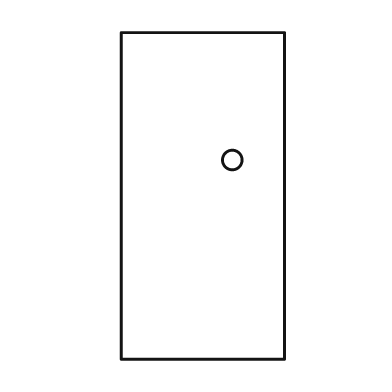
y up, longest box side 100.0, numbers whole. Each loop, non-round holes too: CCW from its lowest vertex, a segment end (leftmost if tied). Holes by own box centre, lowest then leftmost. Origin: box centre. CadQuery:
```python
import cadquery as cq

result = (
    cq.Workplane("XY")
    .moveTo(-25.0, -50.0)
    .lineTo(25.0, -50.0)
    .lineTo(25.0, 50.0)
    .lineTo(-25.0, 50.0)
    .close()
    .moveTo(9.0, 11.0)
    .circle(3.0)
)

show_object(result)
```